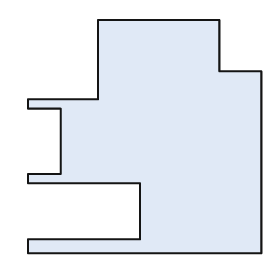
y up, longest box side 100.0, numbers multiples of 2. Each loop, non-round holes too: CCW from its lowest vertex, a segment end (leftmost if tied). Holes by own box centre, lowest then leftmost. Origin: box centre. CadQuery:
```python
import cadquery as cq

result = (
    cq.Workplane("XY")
    .moveTo(-50.0, -50.0)
    .lineTo(50.0, -50.0)
    .lineTo(50.0, 28.0)
    .lineTo(32.0, 28.0)
    .lineTo(32.0, 50.0)
    .lineTo(-20.0, 50.0)
    .lineTo(-20.0, 16.0)
    .lineTo(-50.0, 16.0)
    .lineTo(-50.0, 12.0)
    .lineTo(-36.0, 12.0)
    .lineTo(-36.0, -16.0)
    .lineTo(-50.0, -16.0)
    .lineTo(-50.0, -20.0)
    .lineTo(-2.0, -20.0)
    .lineTo(-2.0, -44.0)
    .lineTo(-50.0, -44.0)
    .close()
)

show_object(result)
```